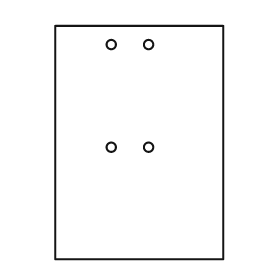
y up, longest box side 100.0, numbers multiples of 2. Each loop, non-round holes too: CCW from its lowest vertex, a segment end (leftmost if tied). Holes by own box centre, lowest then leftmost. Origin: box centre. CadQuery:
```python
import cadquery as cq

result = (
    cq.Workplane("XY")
    .moveTo(-36.0, -50.0)
    .lineTo(36.0, -50.0)
    .lineTo(36.0, 50.0)
    .lineTo(-36.0, 50.0)
    .close()
    .moveTo(-12.0, -2.0)
    .circle(2.0)
    .moveTo(4.0, -2.0)
    .circle(2.0)
    .moveTo(-12.0, 42.0)
    .circle(2.0)
    .moveTo(4.0, 42.0)
    .circle(2.0)
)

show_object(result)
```